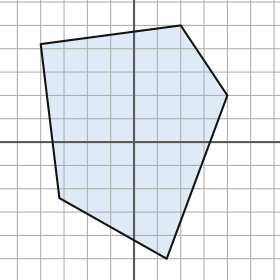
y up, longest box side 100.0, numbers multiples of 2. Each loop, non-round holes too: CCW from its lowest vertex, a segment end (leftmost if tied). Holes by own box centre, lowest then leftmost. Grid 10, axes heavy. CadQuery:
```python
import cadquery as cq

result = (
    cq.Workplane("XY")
    .moveTo(14.0, -50.0)
    .lineTo(40.0, 20.0)
    .lineTo(20.0, 50.0)
    .lineTo(-40.0, 42.0)
    .lineTo(-32.0, -24.0)
    .close()
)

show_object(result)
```